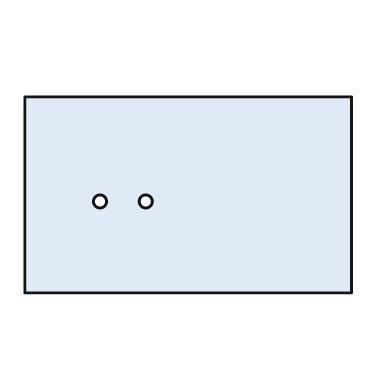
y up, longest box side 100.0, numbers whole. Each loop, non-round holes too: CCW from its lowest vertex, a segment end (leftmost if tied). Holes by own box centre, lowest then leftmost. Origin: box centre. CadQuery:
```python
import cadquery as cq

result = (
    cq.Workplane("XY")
    .moveTo(-50.0, -30.0)
    .lineTo(50.0, -30.0)
    .lineTo(50.0, 30.0)
    .lineTo(-50.0, 30.0)
    .close()
    .moveTo(-27.0, -2.0)
    .circle(2.0)
    .moveTo(-13.0, -2.0)
    .circle(2.0)
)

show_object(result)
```